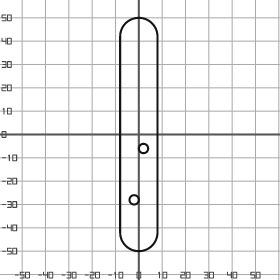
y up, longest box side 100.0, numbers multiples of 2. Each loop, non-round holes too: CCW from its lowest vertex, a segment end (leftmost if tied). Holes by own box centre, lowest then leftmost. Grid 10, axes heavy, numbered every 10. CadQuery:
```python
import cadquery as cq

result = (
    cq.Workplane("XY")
    .moveTo(-8.0, -42.0)
    .threePointArc((0.0, -50.0), (8.0, -42.0))
    .lineTo(8.0, 42.0)
    .threePointArc((0.0, 50.0), (-8.0, 42.0))
    .close()
    .moveTo(-2.0, -28.0)
    .circle(2.0)
    .moveTo(2.0, -6.0)
    .circle(2.0)
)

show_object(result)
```